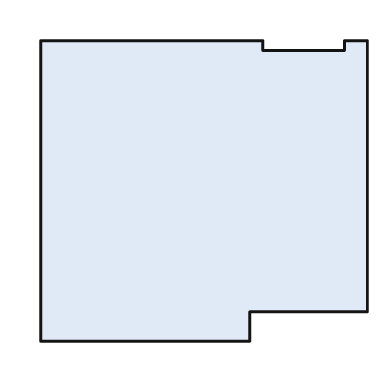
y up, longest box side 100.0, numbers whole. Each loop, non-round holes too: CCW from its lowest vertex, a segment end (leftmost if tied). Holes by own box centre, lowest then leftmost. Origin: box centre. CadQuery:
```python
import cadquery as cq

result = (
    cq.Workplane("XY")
    .moveTo(-50.0, -46.0)
    .lineTo(14.0, -46.0)
    .lineTo(14.0, -37.0)
    .lineTo(50.0, -37.0)
    .lineTo(50.0, 46.0)
    .lineTo(43.0, 46.0)
    .lineTo(43.0, 43.0)
    .lineTo(18.0, 43.0)
    .lineTo(18.0, 46.0)
    .lineTo(-50.0, 46.0)
    .close()
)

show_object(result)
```